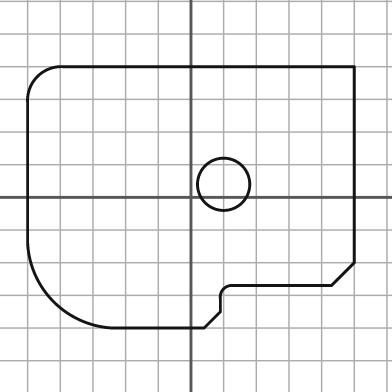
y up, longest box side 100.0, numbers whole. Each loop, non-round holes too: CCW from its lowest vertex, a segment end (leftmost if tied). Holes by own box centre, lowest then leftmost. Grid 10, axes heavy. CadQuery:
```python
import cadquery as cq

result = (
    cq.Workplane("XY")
    .moveTo(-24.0, -40.0)
    .lineTo(4.0, -40.0)
    .lineTo(9.0, -35.0)
    .lineTo(9.0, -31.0)
    .threePointArc((10.0, -28.0), (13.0, -27.0))
    .lineTo(43.0, -27.0)
    .lineTo(50.0, -20.0)
    .lineTo(50.0, 40.0)
    .lineTo(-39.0, 40.0)
    .threePointArc((-47.0, 37.0), (-50.0, 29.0))
    .lineTo(-50.0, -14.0)
    .threePointArc((-42.0, -32.0), (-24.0, -40.0))
    .close()
    .moveTo(10.0, 4.0)
    .circle(8.0)
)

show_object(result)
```